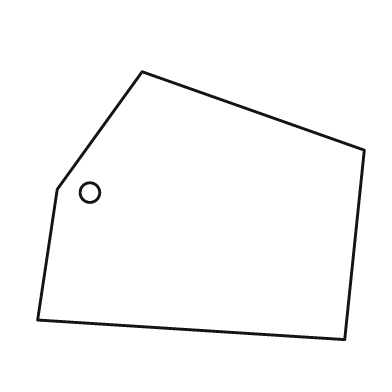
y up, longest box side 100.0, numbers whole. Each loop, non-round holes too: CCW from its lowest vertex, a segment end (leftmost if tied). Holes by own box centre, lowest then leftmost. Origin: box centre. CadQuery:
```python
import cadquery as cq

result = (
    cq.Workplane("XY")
    .moveTo(44.0, -41.0)
    .lineTo(50.0, 17.0)
    .lineTo(-18.0, 41.0)
    .lineTo(-44.0, 5.0)
    .lineTo(-50.0, -35.0)
    .close()
    .moveTo(-34.0, 4.0)
    .circle(3.0)
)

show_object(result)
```